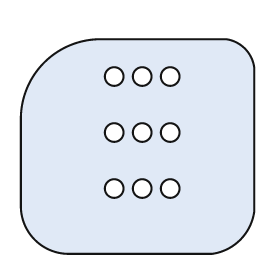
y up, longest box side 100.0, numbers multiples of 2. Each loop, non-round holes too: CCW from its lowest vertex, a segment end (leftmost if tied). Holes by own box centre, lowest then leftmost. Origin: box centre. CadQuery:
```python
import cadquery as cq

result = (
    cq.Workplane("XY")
    .moveTo(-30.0, -46.0)
    .lineTo(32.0, -46.0)
    .threePointArc((44.0, -40.0), (50.0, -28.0))
    .lineTo(50.0, 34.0)
    .threePointArc((46.0, 42.0), (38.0, 46.0))
    .lineTo(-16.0, 46.0)
    .threePointArc((-40.0, 36.0), (-50.0, 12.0))
    .lineTo(-50.0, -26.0)
    .threePointArc((-44.0, -40.0), (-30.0, -46.0))
    .close()
    .moveTo(-10.0, -18.0)
    .circle(4.0)
    .moveTo(2.0, -18.0)
    .circle(4.0)
    .moveTo(14.0, -18.0)
    .circle(4.0)
    .moveTo(-10.0, 6.0)
    .circle(4.0)
    .moveTo(2.0, 6.0)
    .circle(4.0)
    .moveTo(14.0, 6.0)
    .circle(4.0)
    .moveTo(-10.0, 30.0)
    .circle(4.0)
    .moveTo(2.0, 30.0)
    .circle(4.0)
    .moveTo(14.0, 30.0)
    .circle(4.0)
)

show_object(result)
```